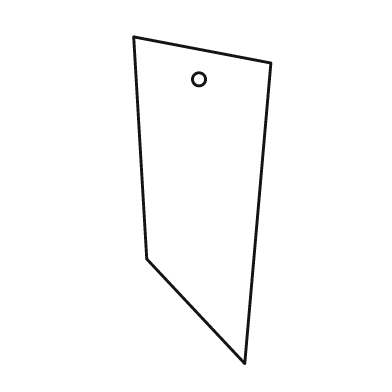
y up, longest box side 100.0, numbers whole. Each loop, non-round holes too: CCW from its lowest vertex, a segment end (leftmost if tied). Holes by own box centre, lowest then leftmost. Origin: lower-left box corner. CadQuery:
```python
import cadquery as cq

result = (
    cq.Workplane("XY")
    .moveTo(34.0, 0.0)
    .lineTo(42.0, 92.0)
    .lineTo(0.0, 100.0)
    .lineTo(4.0, 32.0)
    .close()
    .moveTo(20.0, 87.0)
    .circle(2.0)
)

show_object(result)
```